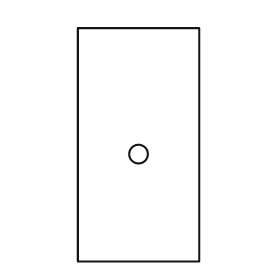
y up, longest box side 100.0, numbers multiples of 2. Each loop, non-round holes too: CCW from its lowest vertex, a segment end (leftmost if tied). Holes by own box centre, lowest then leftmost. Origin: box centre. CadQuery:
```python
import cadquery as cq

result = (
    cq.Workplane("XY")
    .moveTo(-26.0, -50.0)
    .lineTo(26.0, -50.0)
    .lineTo(26.0, 50.0)
    .lineTo(-26.0, 50.0)
    .close()
    .moveTo(0.0, -4.0)
    .circle(4.0)
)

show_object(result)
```